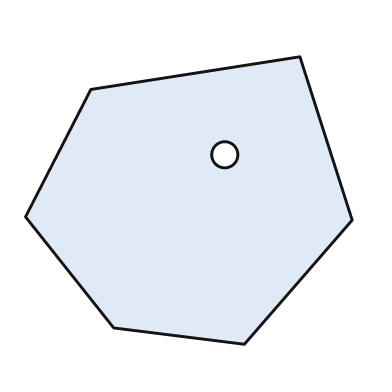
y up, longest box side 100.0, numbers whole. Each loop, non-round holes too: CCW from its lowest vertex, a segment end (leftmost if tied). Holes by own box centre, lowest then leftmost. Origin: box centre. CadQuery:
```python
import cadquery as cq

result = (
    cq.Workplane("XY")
    .moveTo(17.0, -44.0)
    .lineTo(50.0, -6.0)
    .lineTo(34.0, 44.0)
    .lineTo(-30.0, 34.0)
    .lineTo(-50.0, -5.0)
    .lineTo(-23.0, -39.0)
    .close()
    .moveTo(11.0, 14.0)
    .circle(4.0)
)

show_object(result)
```